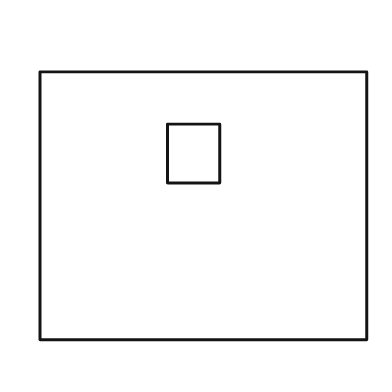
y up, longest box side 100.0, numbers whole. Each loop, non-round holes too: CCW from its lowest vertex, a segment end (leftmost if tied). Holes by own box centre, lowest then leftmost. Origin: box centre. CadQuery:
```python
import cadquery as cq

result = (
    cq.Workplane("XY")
    .moveTo(-50.0, -41.0)
    .lineTo(50.0, -41.0)
    .lineTo(50.0, 41.0)
    .lineTo(-50.0, 41.0)
    .close()
    .moveTo(-11.0, 7.0)
    .lineTo(5.0, 7.0)
    .lineTo(5.0, 25.0)
    .lineTo(-11.0, 25.0)
    .close()
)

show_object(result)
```